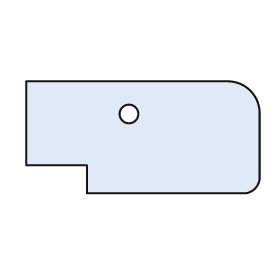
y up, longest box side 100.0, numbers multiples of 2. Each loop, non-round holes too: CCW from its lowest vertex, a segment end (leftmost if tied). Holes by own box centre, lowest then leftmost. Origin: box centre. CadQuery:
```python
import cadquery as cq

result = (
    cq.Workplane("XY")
    .moveTo(-24.0, -24.0)
    .lineTo(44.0, -24.0)
    .threePointArc((48.0, -22.0), (50.0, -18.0))
    .lineTo(50.0, 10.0)
    .threePointArc((46.0, 20.0), (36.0, 24.0))
    .lineTo(-50.0, 24.0)
    .lineTo(-50.0, -12.0)
    .lineTo(-24.0, -12.0)
    .close()
    .moveTo(-6.0, 10.0)
    .circle(4.0)
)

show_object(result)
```